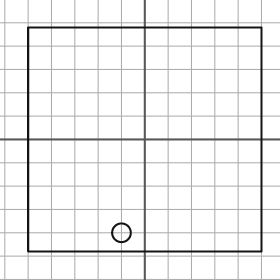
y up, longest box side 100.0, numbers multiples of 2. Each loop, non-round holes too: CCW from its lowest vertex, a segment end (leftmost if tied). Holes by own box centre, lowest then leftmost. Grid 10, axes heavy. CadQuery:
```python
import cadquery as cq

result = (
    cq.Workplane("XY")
    .moveTo(-50.0, -48.0)
    .lineTo(50.0, -48.0)
    .lineTo(50.0, 48.0)
    .lineTo(-50.0, 48.0)
    .close()
    .moveTo(-10.0, -40.0)
    .circle(4.0)
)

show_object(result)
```